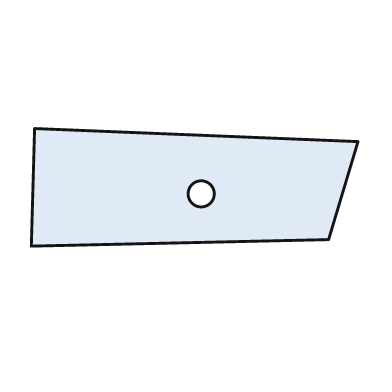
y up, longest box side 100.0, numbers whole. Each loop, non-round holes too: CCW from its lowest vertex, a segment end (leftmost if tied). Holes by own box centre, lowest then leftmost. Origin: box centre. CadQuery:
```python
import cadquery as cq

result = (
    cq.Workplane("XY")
    .moveTo(-50.0, -18.0)
    .lineTo(41.0, -16.0)
    .lineTo(50.0, 14.0)
    .lineTo(-49.0, 18.0)
    .close()
    .moveTo(2.0, -2.0)
    .circle(4.0)
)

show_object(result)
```